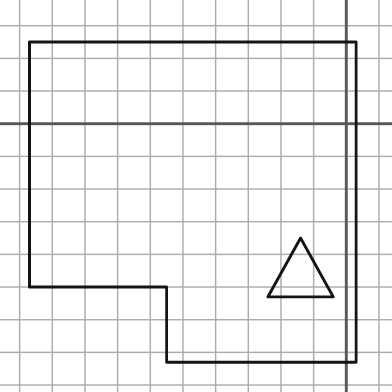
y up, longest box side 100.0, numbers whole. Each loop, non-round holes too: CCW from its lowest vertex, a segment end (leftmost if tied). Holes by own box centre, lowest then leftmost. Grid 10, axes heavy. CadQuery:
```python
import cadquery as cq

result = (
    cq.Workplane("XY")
    .moveTo(-55.0, -73.0)
    .lineTo(3.0, -73.0)
    .lineTo(3.0, 25.0)
    .lineTo(-97.0, 25.0)
    .lineTo(-97.0, -50.0)
    .lineTo(-55.0, -50.0)
    .close()
    .moveTo(-24.0, -53.0)
    .lineTo(-4.0, -53.0)
    .lineTo(-14.0, -35.0)
    .close()
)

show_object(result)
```